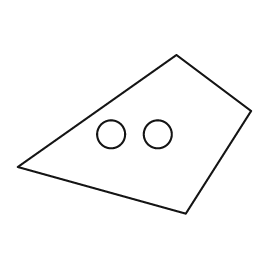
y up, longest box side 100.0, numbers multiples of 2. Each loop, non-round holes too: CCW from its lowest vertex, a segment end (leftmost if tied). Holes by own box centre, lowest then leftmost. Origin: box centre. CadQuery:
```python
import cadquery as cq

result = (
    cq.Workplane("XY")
    .moveTo(22.0, -34.0)
    .lineTo(50.0, 10.0)
    .lineTo(18.0, 34.0)
    .lineTo(-50.0, -14.0)
    .close()
    .moveTo(-10.0, 0.0)
    .circle(6.0)
    .moveTo(10.0, 0.0)
    .circle(6.0)
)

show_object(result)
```